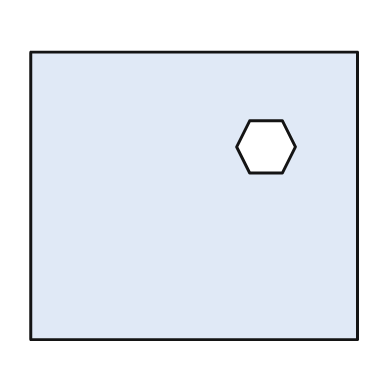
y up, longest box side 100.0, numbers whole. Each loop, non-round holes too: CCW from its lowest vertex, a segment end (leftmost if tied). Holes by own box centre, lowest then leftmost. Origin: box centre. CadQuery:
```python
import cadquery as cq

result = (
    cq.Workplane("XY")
    .moveTo(-50.0, -44.0)
    .lineTo(50.0, -44.0)
    .lineTo(50.0, 44.0)
    .lineTo(-50.0, 44.0)
    .close()
    .moveTo(17.0, 7.0)
    .lineTo(27.0, 7.0)
    .lineTo(31.0, 15.0)
    .lineTo(27.0, 23.0)
    .lineTo(17.0, 23.0)
    .lineTo(13.0, 15.0)
    .close()
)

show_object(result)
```